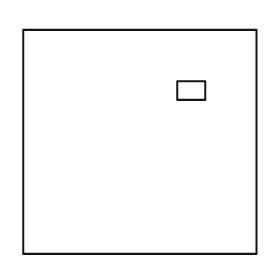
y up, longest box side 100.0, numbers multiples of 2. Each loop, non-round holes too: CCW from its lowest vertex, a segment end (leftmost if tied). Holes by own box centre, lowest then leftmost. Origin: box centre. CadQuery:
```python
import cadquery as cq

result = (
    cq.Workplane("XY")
    .moveTo(-50.0, -48.0)
    .lineTo(50.0, -48.0)
    .lineTo(50.0, 48.0)
    .lineTo(-50.0, 48.0)
    .close()
    .moveTo(16.0, 18.0)
    .lineTo(28.0, 18.0)
    .lineTo(28.0, 26.0)
    .lineTo(16.0, 26.0)
    .close()
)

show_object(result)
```